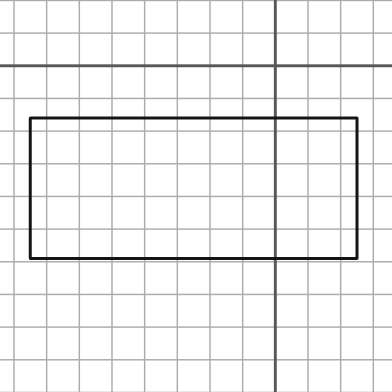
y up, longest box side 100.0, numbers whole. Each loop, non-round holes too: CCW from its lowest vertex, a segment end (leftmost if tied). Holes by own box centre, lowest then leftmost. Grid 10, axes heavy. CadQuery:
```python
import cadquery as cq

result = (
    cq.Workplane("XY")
    .moveTo(-75.0, -59.0)
    .lineTo(25.0, -59.0)
    .lineTo(25.0, -16.0)
    .lineTo(-75.0, -16.0)
    .close()
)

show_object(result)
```